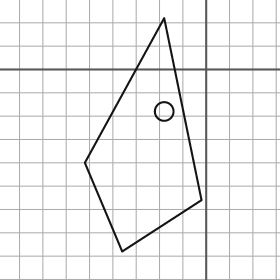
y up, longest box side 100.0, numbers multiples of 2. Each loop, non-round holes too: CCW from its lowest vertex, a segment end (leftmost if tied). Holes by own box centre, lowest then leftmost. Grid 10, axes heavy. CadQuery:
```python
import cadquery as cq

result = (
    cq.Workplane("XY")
    .moveTo(-36.0, -78.0)
    .lineTo(-2.0, -56.0)
    .lineTo(-18.0, 22.0)
    .lineTo(-52.0, -40.0)
    .close()
    .moveTo(-18.0, -18.0)
    .circle(4.0)
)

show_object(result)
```